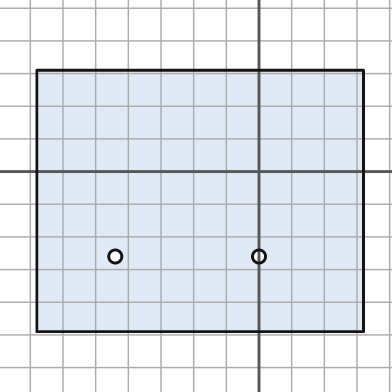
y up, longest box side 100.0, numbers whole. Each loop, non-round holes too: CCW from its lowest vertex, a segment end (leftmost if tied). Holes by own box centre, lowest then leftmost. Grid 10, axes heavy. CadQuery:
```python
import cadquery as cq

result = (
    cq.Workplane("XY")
    .moveTo(-68.0, -49.0)
    .lineTo(32.0, -49.0)
    .lineTo(32.0, 31.0)
    .lineTo(-68.0, 31.0)
    .close()
    .moveTo(-44.0, -26.0)
    .circle(2.0)
    .moveTo(0.0, -26.0)
    .circle(2.0)
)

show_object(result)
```